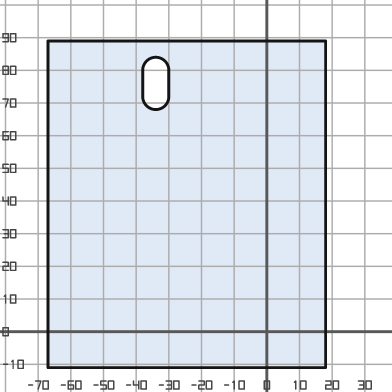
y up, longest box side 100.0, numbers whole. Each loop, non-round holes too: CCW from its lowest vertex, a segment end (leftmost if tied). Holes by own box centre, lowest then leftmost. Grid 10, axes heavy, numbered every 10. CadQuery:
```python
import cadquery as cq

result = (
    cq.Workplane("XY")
    .moveTo(-67.0, -11.0)
    .lineTo(18.0, -11.0)
    .lineTo(18.0, 89.0)
    .lineTo(-67.0, 89.0)
    .close()
    .moveTo(-38.0, 72.0)
    .threePointArc((-34.0, 68.0), (-30.0, 72.0))
    .lineTo(-30.0, 80.0)
    .threePointArc((-34.0, 84.0), (-38.0, 80.0))
    .close()
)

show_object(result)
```